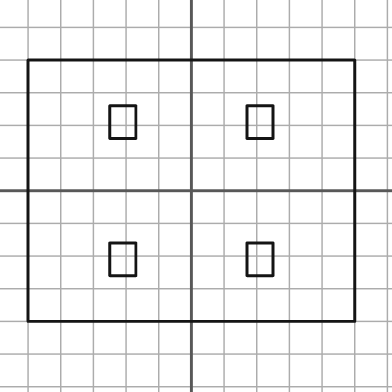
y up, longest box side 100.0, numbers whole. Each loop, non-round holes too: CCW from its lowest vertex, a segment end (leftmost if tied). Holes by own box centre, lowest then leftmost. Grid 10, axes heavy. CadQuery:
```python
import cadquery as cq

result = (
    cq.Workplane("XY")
    .moveTo(-50.0, -40.0)
    .lineTo(50.0, -40.0)
    .lineTo(50.0, 40.0)
    .lineTo(-50.0, 40.0)
    .close()
    .moveTo(-25.0, -26.0)
    .lineTo(-17.0, -26.0)
    .lineTo(-17.0, -16.0)
    .lineTo(-25.0, -16.0)
    .close()
    .moveTo(17.0, -26.0)
    .lineTo(25.0, -26.0)
    .lineTo(25.0, -16.0)
    .lineTo(17.0, -16.0)
    .close()
    .moveTo(-25.0, 16.0)
    .lineTo(-17.0, 16.0)
    .lineTo(-17.0, 26.0)
    .lineTo(-25.0, 26.0)
    .close()
    .moveTo(17.0, 16.0)
    .lineTo(25.0, 16.0)
    .lineTo(25.0, 26.0)
    .lineTo(17.0, 26.0)
    .close()
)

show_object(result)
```